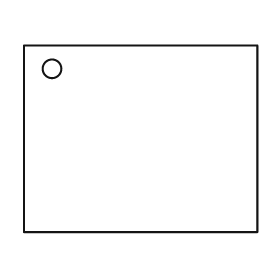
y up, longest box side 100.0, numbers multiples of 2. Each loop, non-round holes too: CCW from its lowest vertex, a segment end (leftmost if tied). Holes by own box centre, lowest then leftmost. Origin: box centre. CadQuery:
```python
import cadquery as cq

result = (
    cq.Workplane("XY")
    .moveTo(-50.0, -40.0)
    .lineTo(50.0, -40.0)
    .lineTo(50.0, 40.0)
    .lineTo(-50.0, 40.0)
    .close()
    .moveTo(-38.0, 30.0)
    .circle(4.0)
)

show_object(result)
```